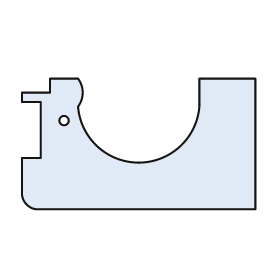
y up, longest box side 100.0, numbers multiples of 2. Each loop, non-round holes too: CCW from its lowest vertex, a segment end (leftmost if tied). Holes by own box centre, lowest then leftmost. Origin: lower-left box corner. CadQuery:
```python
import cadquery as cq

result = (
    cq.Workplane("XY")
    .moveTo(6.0, 0.0)
    .lineTo(100.0, 0.0)
    .lineTo(100.0, 56.0)
    .lineTo(76.0, 56.0)
    .lineTo(76.0, 44.0)
    .threePointArc((50.0, 20.0), (24.0, 44.0))
    .threePointArc((26.0, 50.0), (24.0, 56.0))
    .lineTo(12.0, 56.0)
    .lineTo(12.0, 50.0)
    .lineTo(0.0, 50.0)
    .lineTo(0.0, 46.0)
    .lineTo(8.0, 46.0)
    .lineTo(8.0, 22.0)
    .lineTo(0.0, 22.0)
    .lineTo(0.0, 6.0)
    .threePointArc((2.0, 2.0), (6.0, 0.0))
    .close()
    .moveTo(18.0, 38.0)
    .circle(2.0)
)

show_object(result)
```